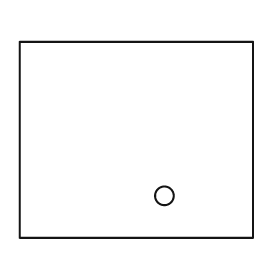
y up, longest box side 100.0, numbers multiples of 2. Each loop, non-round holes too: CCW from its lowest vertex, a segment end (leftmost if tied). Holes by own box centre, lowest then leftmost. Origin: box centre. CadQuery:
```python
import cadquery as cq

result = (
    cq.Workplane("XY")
    .moveTo(-50.0, -42.0)
    .lineTo(50.0, -42.0)
    .lineTo(50.0, 42.0)
    .lineTo(-50.0, 42.0)
    .close()
    .moveTo(12.0, -24.0)
    .circle(4.0)
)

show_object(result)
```